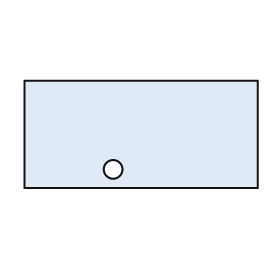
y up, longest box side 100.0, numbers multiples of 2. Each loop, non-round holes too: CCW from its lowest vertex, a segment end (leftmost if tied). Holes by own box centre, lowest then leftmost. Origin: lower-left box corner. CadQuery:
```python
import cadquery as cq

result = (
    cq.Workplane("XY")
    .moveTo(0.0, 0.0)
    .lineTo(100.0, 0.0)
    .lineTo(100.0, 46.0)
    .lineTo(0.0, 46.0)
    .close()
    .moveTo(38.0, 8.0)
    .circle(4.0)
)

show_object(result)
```